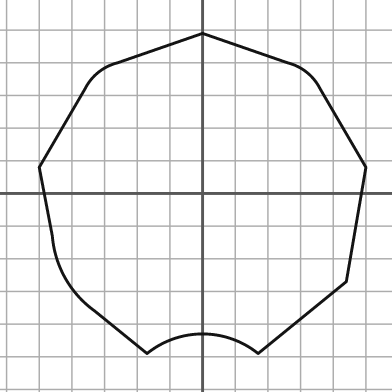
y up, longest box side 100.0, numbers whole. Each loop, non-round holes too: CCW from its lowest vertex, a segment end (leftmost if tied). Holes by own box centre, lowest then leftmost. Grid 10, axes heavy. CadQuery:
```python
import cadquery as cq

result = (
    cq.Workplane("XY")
    .moveTo(-17.0, -49.0)
    .threePointArc((0.0, -43.0), (17.0, -49.0))
    .lineTo(44.0, -27.0)
    .lineTo(50.0, 8.0)
    .lineTo(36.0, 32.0)
    .threePointArc((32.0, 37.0), (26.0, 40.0))
    .lineTo(0.0, 49.0)
    .lineTo(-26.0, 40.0)
    .threePointArc((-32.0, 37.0), (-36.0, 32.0))
    .lineTo(-50.0, 8.0)
    .lineTo(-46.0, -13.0)
    .threePointArc((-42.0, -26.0), (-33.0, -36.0))
    .close()
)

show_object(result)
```